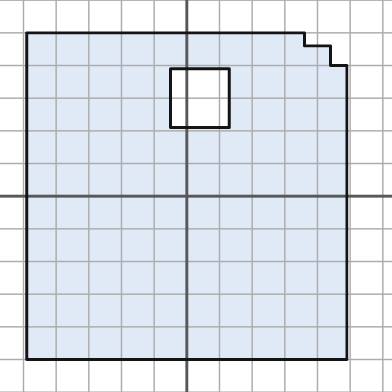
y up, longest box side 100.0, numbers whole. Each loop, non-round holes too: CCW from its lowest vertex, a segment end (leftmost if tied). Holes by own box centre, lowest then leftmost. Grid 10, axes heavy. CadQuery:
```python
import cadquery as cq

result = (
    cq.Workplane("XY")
    .moveTo(-49.0, -50.0)
    .lineTo(49.0, -50.0)
    .lineTo(49.0, 40.0)
    .lineTo(44.0, 40.0)
    .lineTo(44.0, 46.0)
    .lineTo(36.0, 46.0)
    .lineTo(36.0, 50.0)
    .lineTo(-49.0, 50.0)
    .close()
    .moveTo(-5.0, 21.0)
    .lineTo(13.0, 21.0)
    .lineTo(13.0, 39.0)
    .lineTo(-5.0, 39.0)
    .close()
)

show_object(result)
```